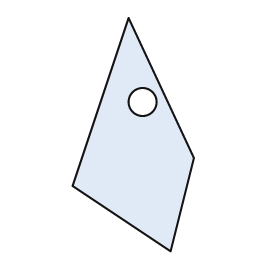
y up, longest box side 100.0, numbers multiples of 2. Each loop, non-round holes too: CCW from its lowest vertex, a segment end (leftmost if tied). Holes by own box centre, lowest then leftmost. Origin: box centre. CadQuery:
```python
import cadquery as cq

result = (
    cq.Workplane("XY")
    .moveTo(16.0, -50.0)
    .lineTo(26.0, -10.0)
    .lineTo(-2.0, 50.0)
    .lineTo(-26.0, -22.0)
    .close()
    .moveTo(4.0, 14.0)
    .circle(6.0)
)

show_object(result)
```